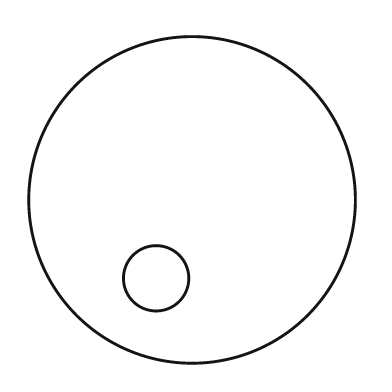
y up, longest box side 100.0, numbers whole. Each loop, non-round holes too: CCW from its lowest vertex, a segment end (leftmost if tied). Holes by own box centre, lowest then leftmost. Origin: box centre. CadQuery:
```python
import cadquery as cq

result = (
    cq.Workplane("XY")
    .moveTo(0.0, 0.0)
    .circle(50.0)
    .moveTo(-11.0, -24.0)
    .circle(10.0)
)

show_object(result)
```